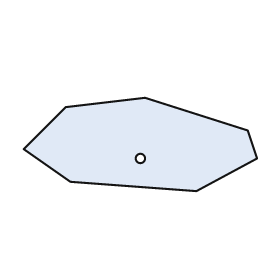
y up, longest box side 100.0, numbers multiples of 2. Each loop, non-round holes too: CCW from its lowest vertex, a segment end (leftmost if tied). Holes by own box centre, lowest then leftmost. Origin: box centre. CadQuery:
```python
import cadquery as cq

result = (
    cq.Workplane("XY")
    .moveTo(24.0, -20.0)
    .lineTo(50.0, -6.0)
    .lineTo(46.0, 6.0)
    .lineTo(2.0, 20.0)
    .lineTo(-32.0, 16.0)
    .lineTo(-50.0, -2.0)
    .lineTo(-30.0, -16.0)
    .close()
    .moveTo(0.0, -6.0)
    .circle(2.0)
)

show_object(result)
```